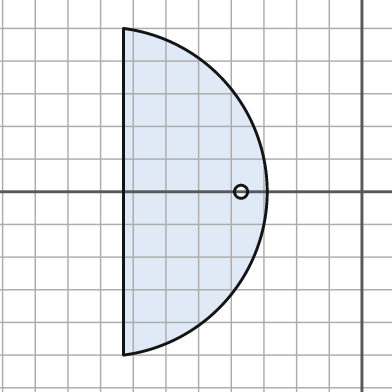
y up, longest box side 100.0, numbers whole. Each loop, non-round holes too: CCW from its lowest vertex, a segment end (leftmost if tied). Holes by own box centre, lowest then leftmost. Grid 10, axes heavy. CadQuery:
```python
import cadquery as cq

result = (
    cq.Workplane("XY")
    .moveTo(-73.0, -50.0)
    .threePointArc((-29.0, 0.0), (-73.0, 50.0))
    .close()
    .moveTo(-37.0, 0.0)
    .circle(2.0)
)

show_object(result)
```